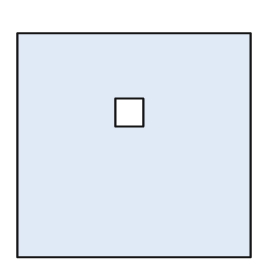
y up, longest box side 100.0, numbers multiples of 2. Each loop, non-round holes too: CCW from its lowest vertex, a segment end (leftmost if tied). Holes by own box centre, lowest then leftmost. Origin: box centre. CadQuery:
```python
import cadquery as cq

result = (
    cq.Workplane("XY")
    .moveTo(-50.0, -48.0)
    .lineTo(50.0, -48.0)
    .lineTo(50.0, 48.0)
    .lineTo(-50.0, 48.0)
    .close()
    .moveTo(-8.0, 8.0)
    .lineTo(4.0, 8.0)
    .lineTo(4.0, 20.0)
    .lineTo(-8.0, 20.0)
    .close()
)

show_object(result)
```